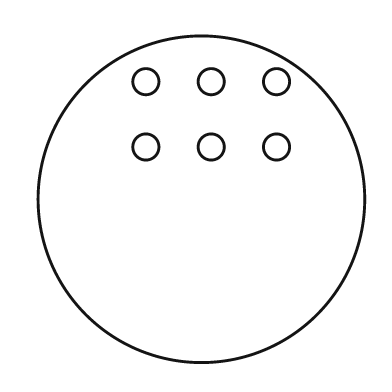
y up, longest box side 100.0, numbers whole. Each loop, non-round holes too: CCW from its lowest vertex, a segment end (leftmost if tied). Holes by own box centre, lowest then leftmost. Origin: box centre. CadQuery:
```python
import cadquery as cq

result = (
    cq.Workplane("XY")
    .moveTo(0.0, 0.0)
    .circle(50.0)
    .moveTo(-17.0, 16.0)
    .circle(4.0)
    .moveTo(3.0, 16.0)
    .circle(4.0)
    .moveTo(23.0, 16.0)
    .circle(4.0)
    .moveTo(-17.0, 36.0)
    .circle(4.0)
    .moveTo(3.0, 36.0)
    .circle(4.0)
    .moveTo(23.0, 36.0)
    .circle(4.0)
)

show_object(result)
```